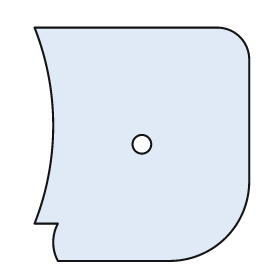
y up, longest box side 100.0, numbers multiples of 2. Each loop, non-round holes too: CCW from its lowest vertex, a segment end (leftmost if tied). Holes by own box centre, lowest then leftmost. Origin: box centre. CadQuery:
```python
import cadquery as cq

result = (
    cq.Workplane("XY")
    .moveTo(-36.0, -50.0)
    .lineTo(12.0, -50.0)
    .threePointArc((36.0, -40.0), (46.0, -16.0))
    .lineTo(46.0, 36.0)
    .threePointArc((42.0, 46.0), (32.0, 50.0))
    .lineTo(-46.0, 50.0)
    .threePointArc((-38.0, 8.0), (-46.0, -34.0))
    .lineTo(-36.0, -34.0)
    .threePointArc((-38.0, -42.0), (-36.0, -50.0))
    .close()
    .moveTo(0.0, 0.0)
    .circle(4.0)
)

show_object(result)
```